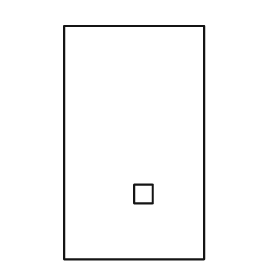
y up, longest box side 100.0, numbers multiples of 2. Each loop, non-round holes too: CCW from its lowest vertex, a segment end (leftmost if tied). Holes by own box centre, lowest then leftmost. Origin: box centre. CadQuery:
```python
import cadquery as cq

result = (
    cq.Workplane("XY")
    .moveTo(-30.0, -50.0)
    .lineTo(30.0, -50.0)
    .lineTo(30.0, 50.0)
    .lineTo(-30.0, 50.0)
    .close()
    .moveTo(0.0, -26.0)
    .lineTo(8.0, -26.0)
    .lineTo(8.0, -18.0)
    .lineTo(0.0, -18.0)
    .close()
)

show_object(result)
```